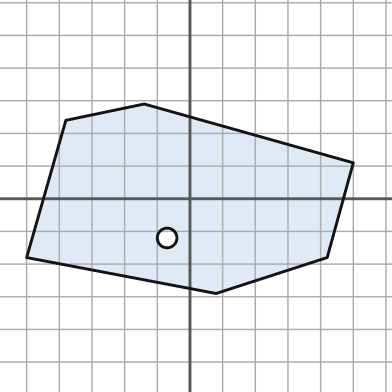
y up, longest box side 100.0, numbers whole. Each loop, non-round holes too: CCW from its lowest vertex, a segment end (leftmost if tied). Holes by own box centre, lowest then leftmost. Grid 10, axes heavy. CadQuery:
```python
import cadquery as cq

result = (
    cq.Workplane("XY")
    .moveTo(8.0, -29.0)
    .lineTo(42.0, -18.0)
    .lineTo(50.0, 11.0)
    .lineTo(-14.0, 29.0)
    .lineTo(-38.0, 24.0)
    .lineTo(-50.0, -18.0)
    .close()
    .moveTo(-7.0, -12.0)
    .circle(3.0)
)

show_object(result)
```